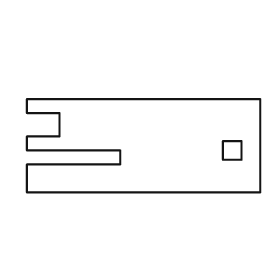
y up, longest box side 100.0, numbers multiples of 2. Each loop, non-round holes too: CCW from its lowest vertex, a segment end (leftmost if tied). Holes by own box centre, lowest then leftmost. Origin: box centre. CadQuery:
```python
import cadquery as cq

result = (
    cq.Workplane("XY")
    .moveTo(-50.0, -20.0)
    .lineTo(50.0, -20.0)
    .lineTo(50.0, 20.0)
    .lineTo(-50.0, 20.0)
    .lineTo(-50.0, 14.0)
    .lineTo(-36.0, 14.0)
    .lineTo(-36.0, 4.0)
    .lineTo(-50.0, 4.0)
    .lineTo(-50.0, -2.0)
    .lineTo(-10.0, -2.0)
    .lineTo(-10.0, -8.0)
    .lineTo(-50.0, -8.0)
    .close()
    .moveTo(34.0, -6.0)
    .lineTo(42.0, -6.0)
    .lineTo(42.0, 2.0)
    .lineTo(34.0, 2.0)
    .close()
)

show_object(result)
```